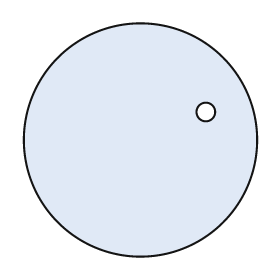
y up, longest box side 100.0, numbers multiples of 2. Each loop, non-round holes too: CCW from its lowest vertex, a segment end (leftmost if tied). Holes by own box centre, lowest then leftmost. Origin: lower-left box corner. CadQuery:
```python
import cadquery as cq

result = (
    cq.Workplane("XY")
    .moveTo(50.0, 50.0)
    .circle(50.0)
    .moveTo(78.0, 62.0)
    .circle(4.0)
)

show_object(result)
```